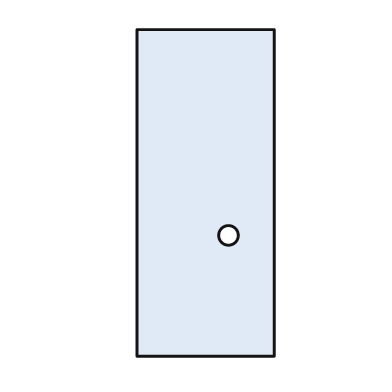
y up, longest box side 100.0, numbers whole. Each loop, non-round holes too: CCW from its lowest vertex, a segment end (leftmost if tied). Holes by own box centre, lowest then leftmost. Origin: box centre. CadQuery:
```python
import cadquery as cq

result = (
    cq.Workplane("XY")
    .moveTo(-21.0, -50.0)
    .lineTo(21.0, -50.0)
    .lineTo(21.0, 50.0)
    .lineTo(-21.0, 50.0)
    .close()
    .moveTo(7.0, -13.0)
    .circle(3.0)
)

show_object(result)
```